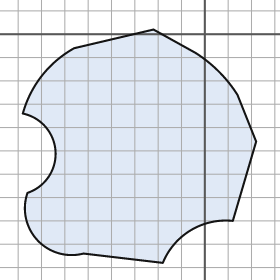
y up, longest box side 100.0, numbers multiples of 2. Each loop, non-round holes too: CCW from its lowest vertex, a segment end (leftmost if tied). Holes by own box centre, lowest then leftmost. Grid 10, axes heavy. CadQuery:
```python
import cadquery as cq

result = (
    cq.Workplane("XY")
    .moveTo(-18.0, -98.0)
    .threePointArc((-6.0, -84.0), (12.0, -80.0))
    .lineTo(22.0, -46.0)
    .lineTo(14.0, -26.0)
    .threePointArc((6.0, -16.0), (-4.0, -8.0))
    .lineTo(-22.0, 2.0)
    .lineTo(-56.0, -6.0)
    .threePointArc((-70.0, -18.0), (-78.0, -34.0))
    .threePointArc((-64.0, -50.0), (-76.0, -68.0))
    .threePointArc((-72.0, -88.0), (-52.0, -94.0))
    .close()
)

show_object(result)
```